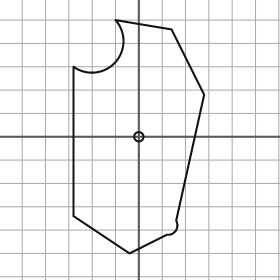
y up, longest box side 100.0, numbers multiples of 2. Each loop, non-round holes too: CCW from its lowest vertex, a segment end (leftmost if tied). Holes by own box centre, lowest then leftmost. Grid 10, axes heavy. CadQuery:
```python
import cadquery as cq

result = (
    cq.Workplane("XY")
    .moveTo(-4.0, -50.0)
    .lineTo(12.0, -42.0)
    .threePointArc((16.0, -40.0), (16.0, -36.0))
    .lineTo(28.0, 18.0)
    .lineTo(14.0, 46.0)
    .lineTo(-10.0, 50.0)
    .threePointArc((-10.0, 32.0), (-28.0, 30.0))
    .lineTo(-28.0, -34.0)
    .close()
    .moveTo(0.0, 0.0)
    .circle(2.0)
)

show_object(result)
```